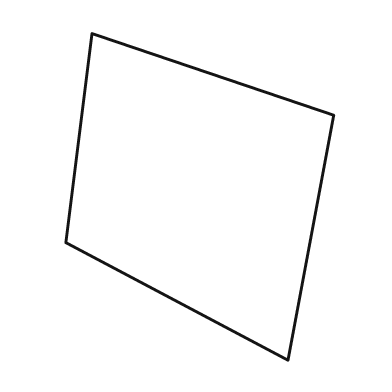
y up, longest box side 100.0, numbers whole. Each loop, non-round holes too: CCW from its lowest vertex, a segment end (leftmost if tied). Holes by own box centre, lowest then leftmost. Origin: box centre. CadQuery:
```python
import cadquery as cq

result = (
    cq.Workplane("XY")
    .moveTo(27.0, -50.0)
    .lineTo(41.0, 25.0)
    .lineTo(-33.0, 50.0)
    .lineTo(-41.0, -14.0)
    .close()
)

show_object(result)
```